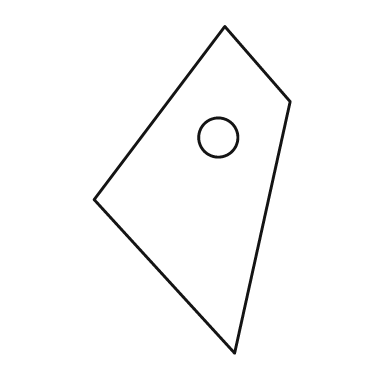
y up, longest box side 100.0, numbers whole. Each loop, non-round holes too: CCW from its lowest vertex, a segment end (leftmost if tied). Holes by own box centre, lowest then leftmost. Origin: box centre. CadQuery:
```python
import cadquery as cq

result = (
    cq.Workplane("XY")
    .moveTo(13.0, -50.0)
    .lineTo(30.0, 27.0)
    .lineTo(10.0, 50.0)
    .lineTo(-30.0, -3.0)
    .close()
    .moveTo(8.0, 16.0)
    .circle(6.0)
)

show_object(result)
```